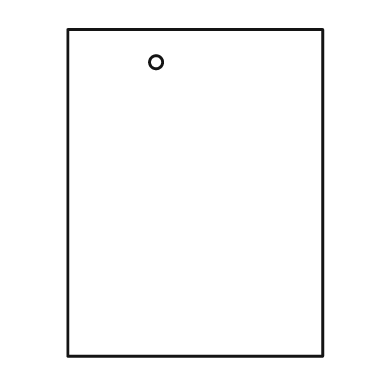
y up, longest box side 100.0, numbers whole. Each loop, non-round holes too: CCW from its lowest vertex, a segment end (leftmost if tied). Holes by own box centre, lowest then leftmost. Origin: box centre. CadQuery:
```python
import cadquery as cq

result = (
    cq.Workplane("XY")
    .moveTo(-39.0, -50.0)
    .lineTo(39.0, -50.0)
    .lineTo(39.0, 50.0)
    .lineTo(-39.0, 50.0)
    .close()
    .moveTo(-12.0, 40.0)
    .circle(2.0)
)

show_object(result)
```